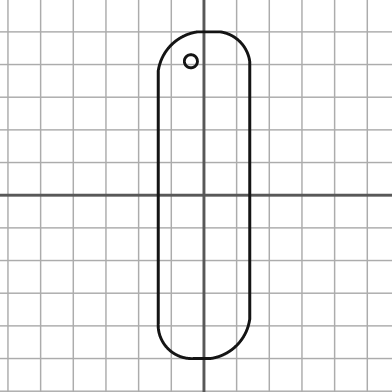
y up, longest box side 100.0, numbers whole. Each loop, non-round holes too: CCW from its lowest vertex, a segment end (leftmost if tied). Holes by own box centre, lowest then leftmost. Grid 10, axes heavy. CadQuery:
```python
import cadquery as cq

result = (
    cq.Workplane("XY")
    .moveTo(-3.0, -50.0)
    .lineTo(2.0, -50.0)
    .threePointArc((10.0, -46.0), (14.0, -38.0))
    .lineTo(14.0, 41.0)
    .threePointArc((11.0, 47.0), (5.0, 50.0))
    .lineTo(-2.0, 50.0)
    .threePointArc((-10.0, 46.0), (-14.0, 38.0))
    .lineTo(-14.0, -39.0)
    .threePointArc((-11.0, -47.0), (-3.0, -50.0))
    .close()
    .moveTo(-4.0, 41.0)
    .circle(2.0)
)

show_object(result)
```